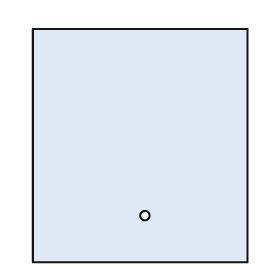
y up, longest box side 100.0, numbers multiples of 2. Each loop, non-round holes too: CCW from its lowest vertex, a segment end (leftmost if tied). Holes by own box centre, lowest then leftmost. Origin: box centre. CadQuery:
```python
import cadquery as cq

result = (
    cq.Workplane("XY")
    .moveTo(-46.0, -50.0)
    .lineTo(46.0, -50.0)
    .lineTo(46.0, 50.0)
    .lineTo(-46.0, 50.0)
    .close()
    .moveTo(2.0, -30.0)
    .circle(2.0)
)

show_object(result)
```